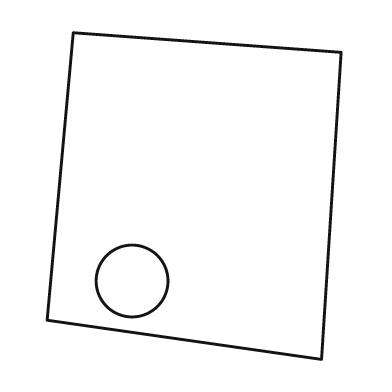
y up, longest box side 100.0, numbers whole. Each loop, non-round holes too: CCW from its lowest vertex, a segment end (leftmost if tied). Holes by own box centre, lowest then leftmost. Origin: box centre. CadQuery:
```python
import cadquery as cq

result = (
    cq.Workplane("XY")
    .moveTo(39.0, -50.0)
    .lineTo(45.0, 44.0)
    .lineTo(-37.0, 50.0)
    .lineTo(-45.0, -38.0)
    .close()
    .moveTo(-19.0, -26.0)
    .circle(11.0)
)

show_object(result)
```